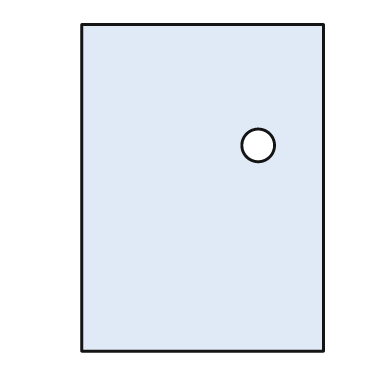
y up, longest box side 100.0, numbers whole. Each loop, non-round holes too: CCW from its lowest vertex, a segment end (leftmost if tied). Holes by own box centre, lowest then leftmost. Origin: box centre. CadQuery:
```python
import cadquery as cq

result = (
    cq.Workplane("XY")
    .moveTo(-37.0, -50.0)
    .lineTo(37.0, -50.0)
    .lineTo(37.0, 50.0)
    .lineTo(-37.0, 50.0)
    .close()
    .moveTo(17.0, 13.0)
    .circle(5.0)
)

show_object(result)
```